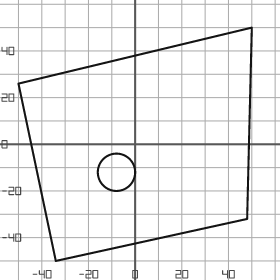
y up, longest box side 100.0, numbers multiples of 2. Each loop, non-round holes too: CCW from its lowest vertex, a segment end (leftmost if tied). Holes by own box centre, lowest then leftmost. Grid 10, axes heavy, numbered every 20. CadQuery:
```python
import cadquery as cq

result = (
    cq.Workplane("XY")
    .moveTo(-34.0, -50.0)
    .lineTo(48.0, -32.0)
    .lineTo(50.0, 50.0)
    .lineTo(-50.0, 26.0)
    .close()
    .moveTo(-8.0, -12.0)
    .circle(8.0)
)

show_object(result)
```